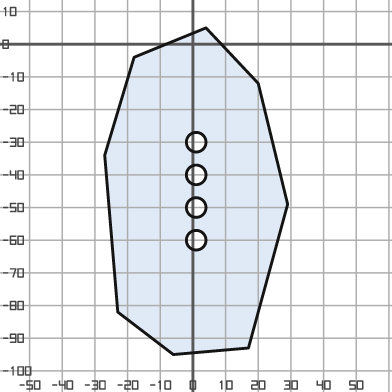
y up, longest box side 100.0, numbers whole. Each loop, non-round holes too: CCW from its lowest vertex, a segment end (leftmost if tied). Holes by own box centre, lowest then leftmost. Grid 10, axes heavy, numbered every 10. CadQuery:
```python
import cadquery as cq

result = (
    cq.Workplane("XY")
    .moveTo(-6.0, -95.0)
    .lineTo(17.0, -93.0)
    .lineTo(29.0, -49.0)
    .lineTo(20.0, -12.0)
    .lineTo(4.0, 5.0)
    .lineTo(-18.0, -4.0)
    .lineTo(-27.0, -34.0)
    .lineTo(-23.0, -82.0)
    .close()
    .moveTo(1.0, -60.0)
    .circle(3.0)
    .moveTo(1.0, -50.0)
    .circle(3.0)
    .moveTo(1.0, -40.0)
    .circle(3.0)
    .moveTo(1.0, -30.0)
    .circle(3.0)
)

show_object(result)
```